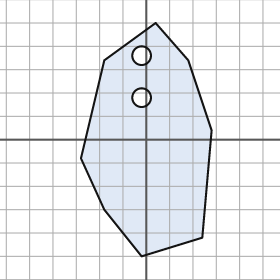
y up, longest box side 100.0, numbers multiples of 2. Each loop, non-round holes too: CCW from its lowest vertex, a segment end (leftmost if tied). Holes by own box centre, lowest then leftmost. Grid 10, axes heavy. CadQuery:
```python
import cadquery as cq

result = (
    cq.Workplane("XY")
    .moveTo(-2.0, -50.0)
    .lineTo(24.0, -42.0)
    .lineTo(28.0, 4.0)
    .lineTo(18.0, 34.0)
    .lineTo(4.0, 50.0)
    .lineTo(-18.0, 34.0)
    .lineTo(-28.0, -8.0)
    .lineTo(-18.0, -30.0)
    .close()
    .moveTo(-2.0, 18.0)
    .circle(4.0)
    .moveTo(-2.0, 36.0)
    .circle(4.0)
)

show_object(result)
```